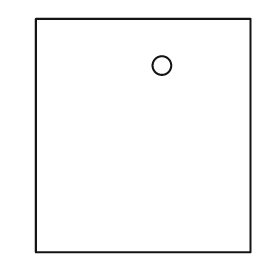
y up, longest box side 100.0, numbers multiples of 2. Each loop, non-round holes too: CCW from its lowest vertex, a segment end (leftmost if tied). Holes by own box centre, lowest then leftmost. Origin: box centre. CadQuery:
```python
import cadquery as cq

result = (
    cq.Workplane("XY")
    .moveTo(-46.0, -50.0)
    .lineTo(46.0, -50.0)
    .lineTo(46.0, 50.0)
    .lineTo(-46.0, 50.0)
    .close()
    .moveTo(8.0, 30.0)
    .circle(4.0)
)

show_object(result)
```